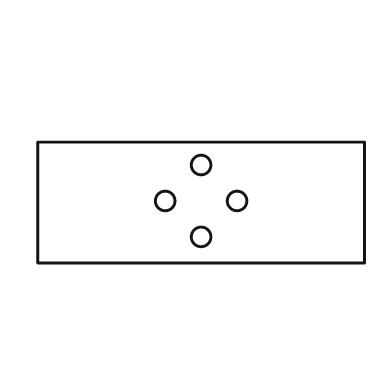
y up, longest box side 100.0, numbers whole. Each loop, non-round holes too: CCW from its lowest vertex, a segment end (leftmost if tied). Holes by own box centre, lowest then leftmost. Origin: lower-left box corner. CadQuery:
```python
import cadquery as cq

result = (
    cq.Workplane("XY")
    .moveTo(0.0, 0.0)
    .lineTo(100.0, 0.0)
    .lineTo(100.0, 37.0)
    .lineTo(0.0, 37.0)
    .close()
    .moveTo(50.0, 8.0)
    .circle(3.0)
    .moveTo(39.0, 19.0)
    .circle(3.0)
    .moveTo(61.0, 19.0)
    .circle(3.0)
    .moveTo(50.0, 30.0)
    .circle(3.0)
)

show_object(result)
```